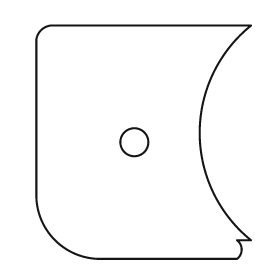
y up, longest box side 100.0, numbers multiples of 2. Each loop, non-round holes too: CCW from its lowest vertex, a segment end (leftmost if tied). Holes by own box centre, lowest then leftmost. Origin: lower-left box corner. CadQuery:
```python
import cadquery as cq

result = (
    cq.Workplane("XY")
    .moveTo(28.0, 0.0)
    .lineTo(86.0, 0.0)
    .threePointArc((88.0, 4.0), (86.0, 8.0))
    .lineTo(92.0, 8.0)
    .threePointArc((70.0, 54.0), (92.0, 100.0))
    .lineTo(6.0, 100.0)
    .threePointArc((2.0, 98.0), (0.0, 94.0))
    .lineTo(0.0, 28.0)
    .threePointArc((8.0, 8.0), (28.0, 0.0))
    .close()
    .moveTo(42.0, 50.0)
    .circle(6.0)
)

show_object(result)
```